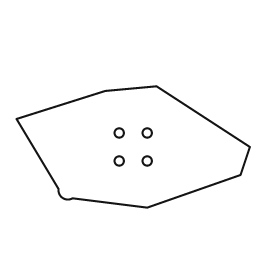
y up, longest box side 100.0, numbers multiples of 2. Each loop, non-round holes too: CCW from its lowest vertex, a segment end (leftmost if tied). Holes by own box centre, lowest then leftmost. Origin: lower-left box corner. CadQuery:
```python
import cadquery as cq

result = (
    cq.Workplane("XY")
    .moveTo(56.0, 0.0)
    .lineTo(96.0, 14.0)
    .lineTo(100.0, 26.0)
    .lineTo(60.0, 52.0)
    .lineTo(38.0, 50.0)
    .lineTo(0.0, 38.0)
    .lineTo(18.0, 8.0)
    .threePointArc((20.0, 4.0), (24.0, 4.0))
    .close()
    .moveTo(44.0, 20.0)
    .circle(2.0)
    .moveTo(56.0, 20.0)
    .circle(2.0)
    .moveTo(44.0, 32.0)
    .circle(2.0)
    .moveTo(56.0, 32.0)
    .circle(2.0)
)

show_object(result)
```